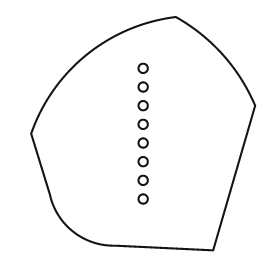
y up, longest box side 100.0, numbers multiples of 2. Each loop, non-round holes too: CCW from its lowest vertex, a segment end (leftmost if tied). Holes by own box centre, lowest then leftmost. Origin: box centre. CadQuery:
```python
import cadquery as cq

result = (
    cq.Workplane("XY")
    .moveTo(30.0, -50.0)
    .lineTo(48.0, 12.0)
    .threePointArc((34.0, 34.0), (14.0, 50.0))
    .threePointArc((-24.0, 34.0), (-48.0, 0.0))
    .lineTo(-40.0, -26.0)
    .threePointArc((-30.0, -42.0), (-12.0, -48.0))
    .close()
    .moveTo(0.0, -28.0)
    .circle(2.0)
    .moveTo(0.0, -20.0)
    .circle(2.0)
    .moveTo(0.0, -12.0)
    .circle(2.0)
    .moveTo(0.0, -4.0)
    .circle(2.0)
    .moveTo(0.0, 4.0)
    .circle(2.0)
    .moveTo(0.0, 12.0)
    .circle(2.0)
    .moveTo(0.0, 20.0)
    .circle(2.0)
    .moveTo(0.0, 28.0)
    .circle(2.0)
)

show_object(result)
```